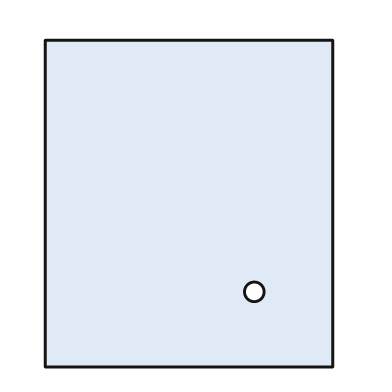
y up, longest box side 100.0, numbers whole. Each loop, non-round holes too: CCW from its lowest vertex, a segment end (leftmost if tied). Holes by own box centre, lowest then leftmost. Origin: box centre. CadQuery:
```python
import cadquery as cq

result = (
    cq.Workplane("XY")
    .moveTo(-44.0, -50.0)
    .lineTo(44.0, -50.0)
    .lineTo(44.0, 50.0)
    .lineTo(-44.0, 50.0)
    .close()
    .moveTo(20.0, -27.0)
    .circle(3.0)
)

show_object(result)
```